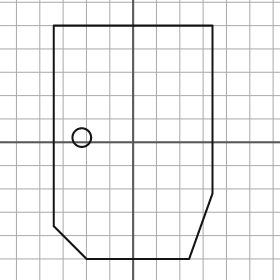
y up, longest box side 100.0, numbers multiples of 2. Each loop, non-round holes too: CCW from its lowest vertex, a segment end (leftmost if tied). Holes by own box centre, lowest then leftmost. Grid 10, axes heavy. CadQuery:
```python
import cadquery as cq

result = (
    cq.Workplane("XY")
    .moveTo(-20.0, -50.0)
    .lineTo(24.0, -50.0)
    .lineTo(34.0, -22.0)
    .lineTo(34.0, 50.0)
    .lineTo(-34.0, 50.0)
    .lineTo(-34.0, -36.0)
    .close()
    .moveTo(-22.0, 2.0)
    .circle(4.0)
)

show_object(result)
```